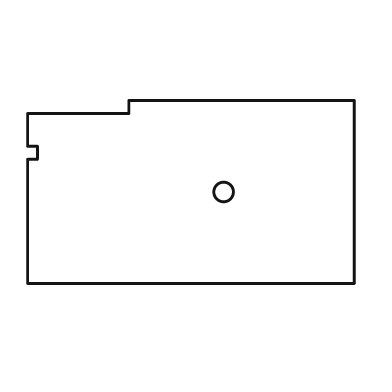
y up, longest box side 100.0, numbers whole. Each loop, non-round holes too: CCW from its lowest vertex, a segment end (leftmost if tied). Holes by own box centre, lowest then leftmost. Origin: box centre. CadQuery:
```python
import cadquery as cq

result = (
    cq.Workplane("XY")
    .moveTo(-50.0, -28.0)
    .lineTo(50.0, -28.0)
    .lineTo(50.0, 28.0)
    .lineTo(-19.0, 28.0)
    .lineTo(-19.0, 24.0)
    .lineTo(-50.0, 24.0)
    .lineTo(-50.0, 14.0)
    .lineTo(-47.0, 14.0)
    .lineTo(-47.0, 10.0)
    .lineTo(-50.0, 10.0)
    .close()
    .moveTo(10.0, 0.0)
    .circle(3.0)
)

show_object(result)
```